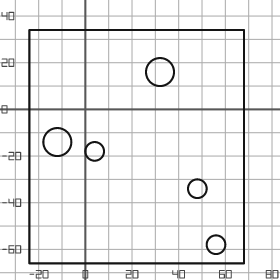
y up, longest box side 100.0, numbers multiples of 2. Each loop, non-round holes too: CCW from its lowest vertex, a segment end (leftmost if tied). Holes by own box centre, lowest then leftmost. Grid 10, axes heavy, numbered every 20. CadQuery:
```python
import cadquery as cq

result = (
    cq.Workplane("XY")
    .moveTo(-24.0, -66.0)
    .lineTo(68.0, -66.0)
    .lineTo(68.0, 34.0)
    .lineTo(-24.0, 34.0)
    .close()
    .moveTo(56.0, -58.0)
    .circle(4.0)
    .moveTo(48.0, -34.0)
    .circle(4.0)
    .moveTo(4.0, -18.0)
    .circle(4.0)
    .moveTo(-12.0, -14.0)
    .circle(6.0)
    .moveTo(32.0, 16.0)
    .circle(6.0)
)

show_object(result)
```